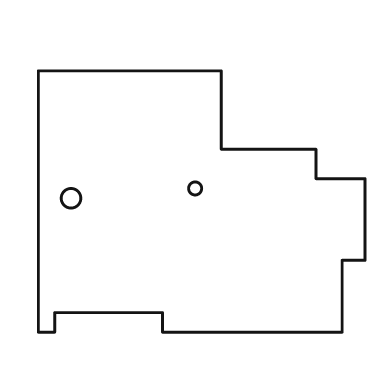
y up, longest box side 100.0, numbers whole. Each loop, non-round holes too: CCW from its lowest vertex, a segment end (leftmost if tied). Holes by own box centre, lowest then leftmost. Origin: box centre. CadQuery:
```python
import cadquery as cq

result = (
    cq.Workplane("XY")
    .moveTo(-50.0, -40.0)
    .lineTo(-45.0, -40.0)
    .lineTo(-45.0, -34.0)
    .lineTo(-12.0, -34.0)
    .lineTo(-12.0, -40.0)
    .lineTo(43.0, -40.0)
    .lineTo(43.0, -18.0)
    .lineTo(50.0, -18.0)
    .lineTo(50.0, 7.0)
    .lineTo(35.0, 7.0)
    .lineTo(35.0, 16.0)
    .lineTo(6.0, 16.0)
    .lineTo(6.0, 40.0)
    .lineTo(-50.0, 40.0)
    .close()
    .moveTo(-40.0, 1.0)
    .circle(3.0)
    .moveTo(-2.0, 4.0)
    .circle(2.0)
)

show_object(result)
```